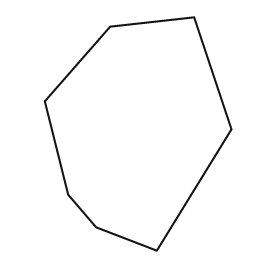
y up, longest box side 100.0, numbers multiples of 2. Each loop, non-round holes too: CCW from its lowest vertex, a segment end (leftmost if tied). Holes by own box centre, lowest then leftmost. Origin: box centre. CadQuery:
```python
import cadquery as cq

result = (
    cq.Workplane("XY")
    .moveTo(8.0, -50.0)
    .lineTo(40.0, 2.0)
    .lineTo(24.0, 50.0)
    .lineTo(-12.0, 46.0)
    .lineTo(-40.0, 14.0)
    .lineTo(-30.0, -26.0)
    .lineTo(-18.0, -40.0)
    .close()
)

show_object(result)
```